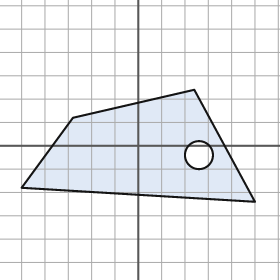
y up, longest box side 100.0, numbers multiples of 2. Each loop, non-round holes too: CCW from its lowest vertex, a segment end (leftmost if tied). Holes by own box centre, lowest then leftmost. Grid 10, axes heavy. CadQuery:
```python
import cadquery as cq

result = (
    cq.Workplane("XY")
    .moveTo(50.0, -24.0)
    .lineTo(24.0, 24.0)
    .lineTo(-28.0, 12.0)
    .lineTo(-50.0, -18.0)
    .close()
    .moveTo(26.0, -4.0)
    .circle(6.0)
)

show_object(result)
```